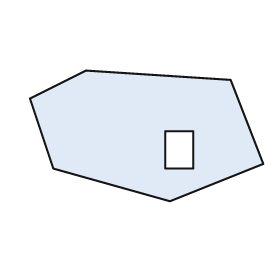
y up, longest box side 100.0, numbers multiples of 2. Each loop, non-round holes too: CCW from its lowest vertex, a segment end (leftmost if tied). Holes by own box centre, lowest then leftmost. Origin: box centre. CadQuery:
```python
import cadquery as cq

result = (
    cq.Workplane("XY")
    .moveTo(10.0, -28.0)
    .lineTo(50.0, -12.0)
    .lineTo(36.0, 24.0)
    .lineTo(-26.0, 28.0)
    .lineTo(-50.0, 16.0)
    .lineTo(-40.0, -14.0)
    .close()
    .moveTo(8.0, -14.0)
    .lineTo(20.0, -14.0)
    .lineTo(20.0, 2.0)
    .lineTo(8.0, 2.0)
    .close()
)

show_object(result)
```